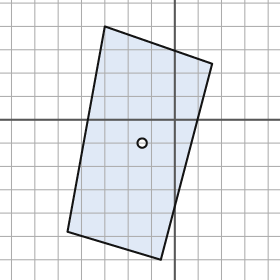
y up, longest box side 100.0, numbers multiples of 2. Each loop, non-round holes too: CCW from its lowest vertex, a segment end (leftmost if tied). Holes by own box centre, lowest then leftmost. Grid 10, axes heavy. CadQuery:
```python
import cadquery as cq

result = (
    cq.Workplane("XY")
    .moveTo(-6.0, -60.0)
    .lineTo(16.0, 24.0)
    .lineTo(-30.0, 40.0)
    .lineTo(-46.0, -48.0)
    .close()
    .moveTo(-14.0, -10.0)
    .circle(2.0)
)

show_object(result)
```